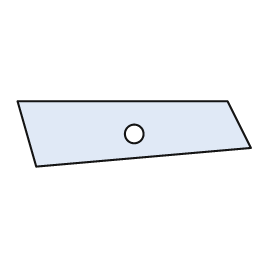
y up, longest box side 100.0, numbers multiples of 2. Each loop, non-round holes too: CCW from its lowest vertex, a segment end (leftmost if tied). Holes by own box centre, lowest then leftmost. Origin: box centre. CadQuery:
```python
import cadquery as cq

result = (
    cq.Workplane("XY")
    .moveTo(-42.0, -14.0)
    .lineTo(50.0, -6.0)
    .lineTo(40.0, 14.0)
    .lineTo(-50.0, 14.0)
    .close()
    .moveTo(0.0, 0.0)
    .circle(4.0)
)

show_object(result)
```